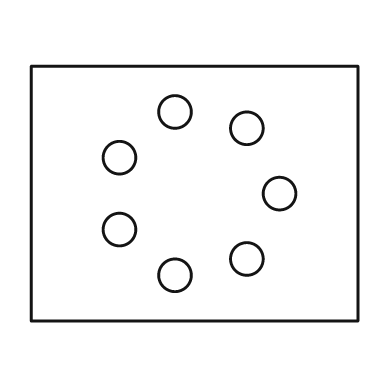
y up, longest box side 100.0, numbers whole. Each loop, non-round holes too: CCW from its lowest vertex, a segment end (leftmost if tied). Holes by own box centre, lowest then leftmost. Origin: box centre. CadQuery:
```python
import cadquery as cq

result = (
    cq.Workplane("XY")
    .moveTo(-50.0, -39.0)
    .lineTo(50.0, -39.0)
    .lineTo(50.0, 39.0)
    .lineTo(-50.0, 39.0)
    .close()
    .moveTo(-6.0, -25.0)
    .circle(5.0)
    .moveTo(16.0, -20.0)
    .circle(5.0)
    .moveTo(-23.0, -11.0)
    .circle(5.0)
    .moveTo(26.0, 0.0)
    .circle(5.0)
    .moveTo(-23.0, 11.0)
    .circle(5.0)
    .moveTo(16.0, 20.0)
    .circle(5.0)
    .moveTo(-6.0, 25.0)
    .circle(5.0)
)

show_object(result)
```